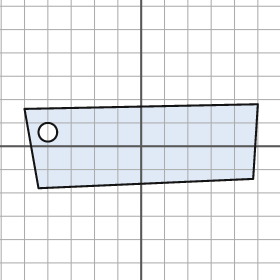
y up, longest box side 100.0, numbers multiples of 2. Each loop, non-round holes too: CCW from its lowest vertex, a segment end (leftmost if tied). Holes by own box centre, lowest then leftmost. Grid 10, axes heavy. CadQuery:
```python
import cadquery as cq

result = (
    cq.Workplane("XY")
    .moveTo(-44.0, -18.0)
    .lineTo(48.0, -14.0)
    .lineTo(50.0, 18.0)
    .lineTo(-50.0, 16.0)
    .close()
    .moveTo(-40.0, 6.0)
    .circle(4.0)
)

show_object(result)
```